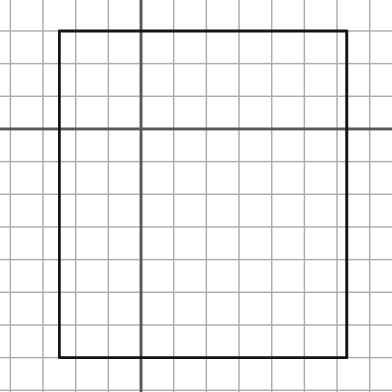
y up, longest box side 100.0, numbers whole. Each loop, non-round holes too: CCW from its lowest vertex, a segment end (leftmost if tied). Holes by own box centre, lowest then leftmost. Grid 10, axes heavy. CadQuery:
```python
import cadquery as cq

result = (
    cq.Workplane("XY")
    .moveTo(-25.0, -70.0)
    .lineTo(63.0, -70.0)
    .lineTo(63.0, 30.0)
    .lineTo(-25.0, 30.0)
    .close()
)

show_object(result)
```